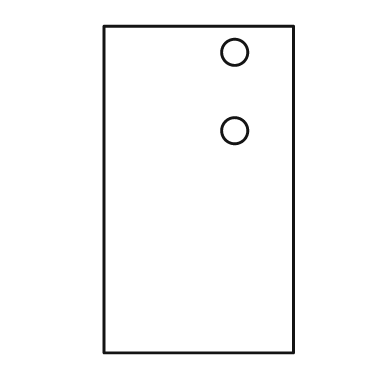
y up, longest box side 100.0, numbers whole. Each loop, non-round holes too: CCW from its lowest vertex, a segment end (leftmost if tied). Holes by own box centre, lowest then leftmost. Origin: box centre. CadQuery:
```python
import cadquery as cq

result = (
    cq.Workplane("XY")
    .moveTo(-29.0, -50.0)
    .lineTo(29.0, -50.0)
    .lineTo(29.0, 50.0)
    .lineTo(-29.0, 50.0)
    .close()
    .moveTo(11.0, 18.0)
    .circle(4.0)
    .moveTo(11.0, 42.0)
    .circle(4.0)
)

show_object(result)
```